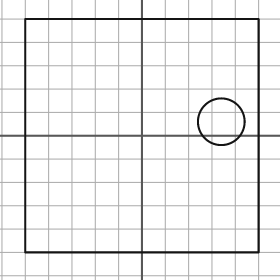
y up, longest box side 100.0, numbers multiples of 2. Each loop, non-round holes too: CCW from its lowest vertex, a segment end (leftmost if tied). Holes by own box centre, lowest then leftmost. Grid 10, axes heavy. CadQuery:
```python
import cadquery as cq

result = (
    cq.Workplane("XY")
    .moveTo(-50.0, -50.0)
    .lineTo(50.0, -50.0)
    .lineTo(50.0, 50.0)
    .lineTo(-50.0, 50.0)
    .close()
    .moveTo(34.0, 6.0)
    .circle(10.0)
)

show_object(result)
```